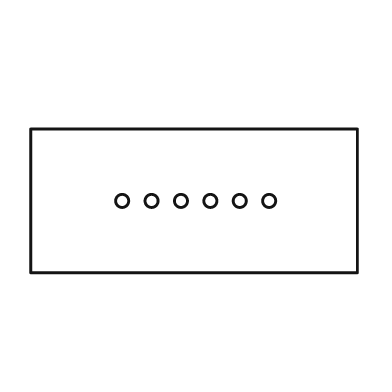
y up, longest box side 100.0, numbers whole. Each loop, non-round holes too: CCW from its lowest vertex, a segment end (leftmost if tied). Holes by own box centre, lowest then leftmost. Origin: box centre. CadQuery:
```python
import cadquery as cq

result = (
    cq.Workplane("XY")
    .moveTo(-50.0, -22.0)
    .lineTo(50.0, -22.0)
    .lineTo(50.0, 22.0)
    .lineTo(-50.0, 22.0)
    .close()
    .moveTo(-22.0, 0.0)
    .circle(2.0)
    .moveTo(-13.0, 0.0)
    .circle(2.0)
    .moveTo(-4.0, 0.0)
    .circle(2.0)
    .moveTo(5.0, 0.0)
    .circle(2.0)
    .moveTo(14.0, 0.0)
    .circle(2.0)
    .moveTo(23.0, 0.0)
    .circle(2.0)
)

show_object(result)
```